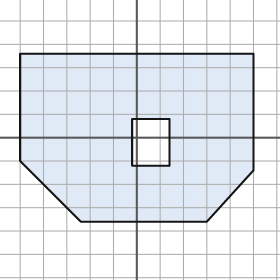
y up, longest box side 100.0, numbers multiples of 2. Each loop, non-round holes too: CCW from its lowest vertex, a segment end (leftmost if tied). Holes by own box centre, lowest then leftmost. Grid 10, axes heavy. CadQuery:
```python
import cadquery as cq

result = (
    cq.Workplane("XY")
    .moveTo(-24.0, -36.0)
    .lineTo(30.0, -36.0)
    .lineTo(50.0, -14.0)
    .lineTo(50.0, 36.0)
    .lineTo(-50.0, 36.0)
    .lineTo(-50.0, -10.0)
    .close()
    .moveTo(-2.0, -12.0)
    .lineTo(14.0, -12.0)
    .lineTo(14.0, 8.0)
    .lineTo(-2.0, 8.0)
    .close()
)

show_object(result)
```